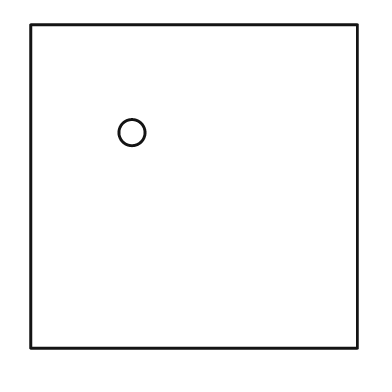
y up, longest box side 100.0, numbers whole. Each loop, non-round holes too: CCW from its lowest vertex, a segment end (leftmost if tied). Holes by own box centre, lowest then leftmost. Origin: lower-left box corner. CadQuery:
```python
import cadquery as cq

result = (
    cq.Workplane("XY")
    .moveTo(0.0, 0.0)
    .lineTo(100.0, 0.0)
    .lineTo(100.0, 99.0)
    .lineTo(0.0, 99.0)
    .close()
    .moveTo(31.0, 66.0)
    .circle(4.0)
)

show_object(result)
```